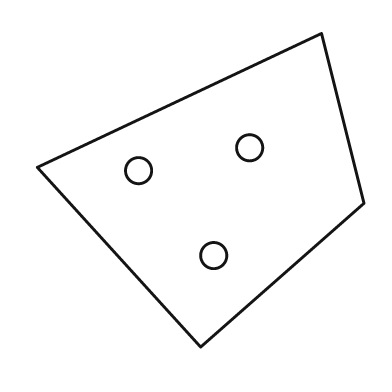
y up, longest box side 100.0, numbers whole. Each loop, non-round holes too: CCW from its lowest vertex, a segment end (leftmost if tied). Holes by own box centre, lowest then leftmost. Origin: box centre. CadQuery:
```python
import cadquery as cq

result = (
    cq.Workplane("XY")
    .moveTo(0.0, -48.0)
    .lineTo(50.0, -4.0)
    .lineTo(37.0, 48.0)
    .lineTo(-50.0, 7.0)
    .close()
    .moveTo(4.0, -20.0)
    .circle(4.0)
    .moveTo(-19.0, 6.0)
    .circle(4.0)
    .moveTo(15.0, 13.0)
    .circle(4.0)
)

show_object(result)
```